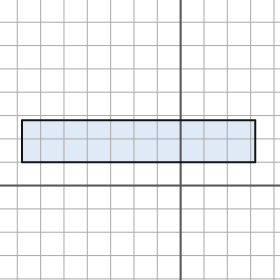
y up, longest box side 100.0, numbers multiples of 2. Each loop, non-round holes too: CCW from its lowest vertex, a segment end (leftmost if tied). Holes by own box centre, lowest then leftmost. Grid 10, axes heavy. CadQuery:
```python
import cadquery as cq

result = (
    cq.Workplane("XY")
    .moveTo(-68.0, 10.0)
    .lineTo(32.0, 10.0)
    .lineTo(32.0, 28.0)
    .lineTo(-68.0, 28.0)
    .close()
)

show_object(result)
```